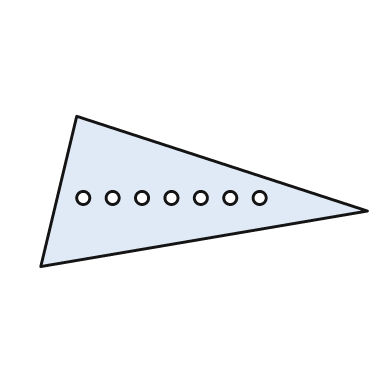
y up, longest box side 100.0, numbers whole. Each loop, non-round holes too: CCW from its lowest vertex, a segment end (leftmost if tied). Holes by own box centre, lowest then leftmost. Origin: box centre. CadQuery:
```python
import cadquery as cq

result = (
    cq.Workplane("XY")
    .moveTo(-50.0, -23.0)
    .lineTo(50.0, -6.0)
    .lineTo(-39.0, 23.0)
    .close()
    .moveTo(-37.0, -2.0)
    .circle(2.0)
    .moveTo(-28.0, -2.0)
    .circle(2.0)
    .moveTo(-19.0, -2.0)
    .circle(2.0)
    .moveTo(-10.0, -2.0)
    .circle(2.0)
    .moveTo(-1.0, -2.0)
    .circle(2.0)
    .moveTo(8.0, -2.0)
    .circle(2.0)
    .moveTo(17.0, -2.0)
    .circle(2.0)
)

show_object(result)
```